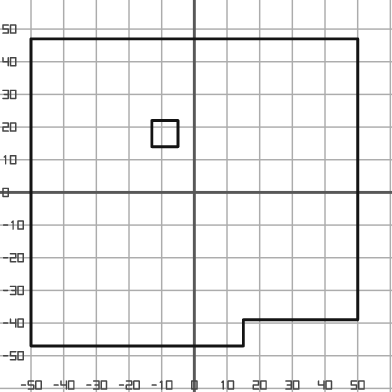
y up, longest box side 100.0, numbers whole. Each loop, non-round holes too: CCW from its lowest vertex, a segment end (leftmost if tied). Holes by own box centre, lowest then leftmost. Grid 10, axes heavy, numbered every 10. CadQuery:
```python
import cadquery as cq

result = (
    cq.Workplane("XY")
    .moveTo(-50.0, -47.0)
    .lineTo(15.0, -47.0)
    .lineTo(15.0, -39.0)
    .lineTo(50.0, -39.0)
    .lineTo(50.0, 47.0)
    .lineTo(-50.0, 47.0)
    .close()
    .moveTo(-13.0, 14.0)
    .lineTo(-5.0, 14.0)
    .lineTo(-5.0, 22.0)
    .lineTo(-13.0, 22.0)
    .close()
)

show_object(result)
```